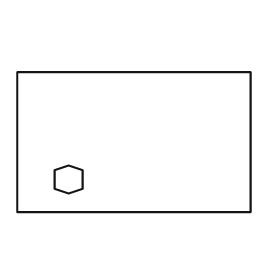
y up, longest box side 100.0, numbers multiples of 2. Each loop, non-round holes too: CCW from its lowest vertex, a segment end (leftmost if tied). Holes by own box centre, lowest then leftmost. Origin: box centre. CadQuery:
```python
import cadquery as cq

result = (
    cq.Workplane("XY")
    .moveTo(-50.0, -30.0)
    .lineTo(50.0, -30.0)
    .lineTo(50.0, 30.0)
    .lineTo(-50.0, 30.0)
    .close()
    .moveTo(-28.0, -22.0)
    .lineTo(-22.0, -20.0)
    .lineTo(-22.0, -12.0)
    .lineTo(-28.0, -10.0)
    .lineTo(-34.0, -12.0)
    .lineTo(-34.0, -20.0)
    .close()
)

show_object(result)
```